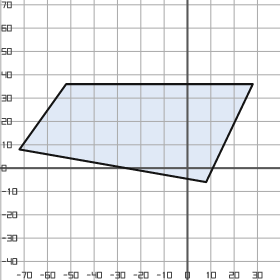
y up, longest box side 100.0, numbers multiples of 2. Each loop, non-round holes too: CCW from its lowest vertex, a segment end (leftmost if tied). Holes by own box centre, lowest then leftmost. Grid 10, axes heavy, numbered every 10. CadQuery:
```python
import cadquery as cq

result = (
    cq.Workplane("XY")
    .moveTo(8.0, -6.0)
    .lineTo(28.0, 36.0)
    .lineTo(-52.0, 36.0)
    .lineTo(-72.0, 8.0)
    .close()
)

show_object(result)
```